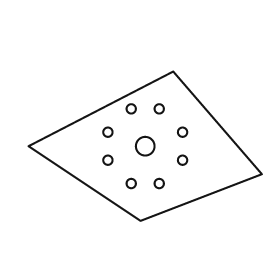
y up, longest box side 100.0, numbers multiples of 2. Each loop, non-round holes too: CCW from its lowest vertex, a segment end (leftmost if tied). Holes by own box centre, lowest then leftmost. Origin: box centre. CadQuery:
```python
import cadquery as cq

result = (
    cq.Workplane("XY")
    .moveTo(-2.0, -32.0)
    .lineTo(50.0, -12.0)
    .lineTo(12.0, 32.0)
    .lineTo(-50.0, 0.0)
    .close()
    .moveTo(-6.0, -16.0)
    .circle(2.0)
    .moveTo(6.0, -16.0)
    .circle(2.0)
    .moveTo(-16.0, -6.0)
    .circle(2.0)
    .moveTo(16.0, -6.0)
    .circle(2.0)
    .moveTo(0.0, 0.0)
    .circle(4.0)
    .moveTo(-16.0, 6.0)
    .circle(2.0)
    .moveTo(16.0, 6.0)
    .circle(2.0)
    .moveTo(-6.0, 16.0)
    .circle(2.0)
    .moveTo(6.0, 16.0)
    .circle(2.0)
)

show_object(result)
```